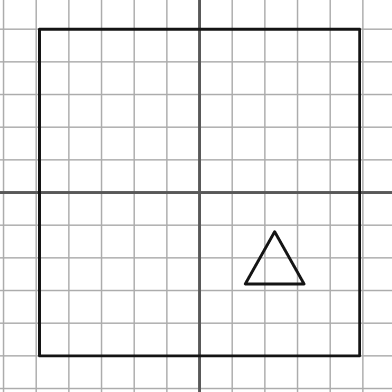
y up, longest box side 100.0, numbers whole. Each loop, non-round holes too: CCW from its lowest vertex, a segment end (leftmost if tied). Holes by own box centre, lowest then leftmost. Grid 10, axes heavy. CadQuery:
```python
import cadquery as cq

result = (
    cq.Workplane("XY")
    .moveTo(-49.0, -50.0)
    .lineTo(49.0, -50.0)
    .lineTo(49.0, 50.0)
    .lineTo(-49.0, 50.0)
    .close()
    .moveTo(14.0, -28.0)
    .lineTo(32.0, -28.0)
    .lineTo(23.0, -12.0)
    .close()
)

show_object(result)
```